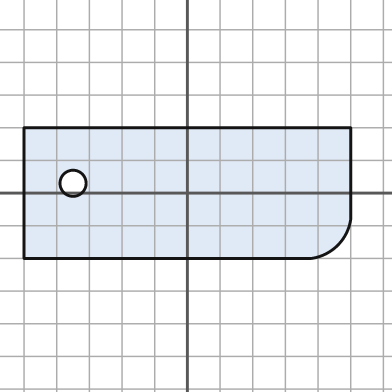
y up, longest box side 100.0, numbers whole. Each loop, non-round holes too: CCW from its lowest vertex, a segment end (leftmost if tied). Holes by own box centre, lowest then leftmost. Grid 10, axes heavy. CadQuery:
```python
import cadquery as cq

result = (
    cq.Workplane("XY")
    .moveTo(-50.0, -20.0)
    .lineTo(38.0, -20.0)
    .threePointArc((46.0, -16.0), (50.0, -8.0))
    .lineTo(50.0, 20.0)
    .lineTo(-50.0, 20.0)
    .close()
    .moveTo(-35.0, 3.0)
    .circle(4.0)
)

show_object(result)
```